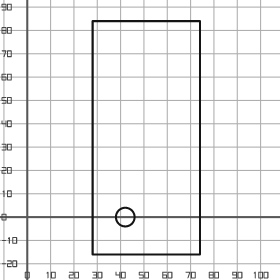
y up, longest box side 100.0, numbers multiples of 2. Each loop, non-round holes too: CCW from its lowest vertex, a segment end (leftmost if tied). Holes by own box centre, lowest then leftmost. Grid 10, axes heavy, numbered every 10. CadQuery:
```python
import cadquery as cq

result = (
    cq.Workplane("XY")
    .moveTo(28.0, -16.0)
    .lineTo(74.0, -16.0)
    .lineTo(74.0, 84.0)
    .lineTo(28.0, 84.0)
    .close()
    .moveTo(42.0, 0.0)
    .circle(4.0)
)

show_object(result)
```